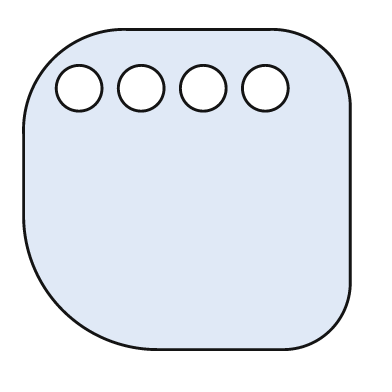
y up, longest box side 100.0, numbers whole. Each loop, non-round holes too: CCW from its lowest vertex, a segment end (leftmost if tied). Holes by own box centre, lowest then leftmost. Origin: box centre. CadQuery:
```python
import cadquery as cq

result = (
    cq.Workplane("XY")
    .moveTo(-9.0, -49.0)
    .lineTo(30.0, -49.0)
    .threePointArc((44.0, -43.0), (50.0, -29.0))
    .lineTo(50.0, 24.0)
    .threePointArc((43.0, 42.0), (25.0, 49.0))
    .lineTo(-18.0, 49.0)
    .threePointArc((-41.0, 40.0), (-50.0, 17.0))
    .lineTo(-50.0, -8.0)
    .threePointArc((-38.0, -37.0), (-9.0, -49.0))
    .close()
    .moveTo(-33.0, 31.0)
    .circle(7.0)
    .moveTo(-14.0, 31.0)
    .circle(7.0)
    .moveTo(5.0, 31.0)
    .circle(7.0)
    .moveTo(24.0, 31.0)
    .circle(7.0)
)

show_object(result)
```